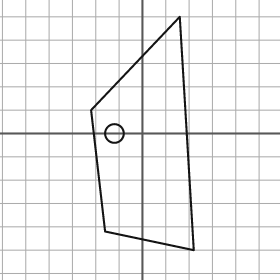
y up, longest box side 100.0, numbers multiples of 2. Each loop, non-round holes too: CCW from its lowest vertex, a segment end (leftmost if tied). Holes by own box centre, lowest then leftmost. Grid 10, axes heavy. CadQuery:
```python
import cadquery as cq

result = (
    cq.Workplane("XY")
    .moveTo(22.0, -50.0)
    .lineTo(16.0, 50.0)
    .lineTo(-22.0, 10.0)
    .lineTo(-16.0, -42.0)
    .close()
    .moveTo(-12.0, 0.0)
    .circle(4.0)
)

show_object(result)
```